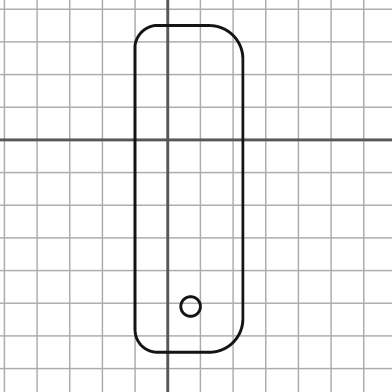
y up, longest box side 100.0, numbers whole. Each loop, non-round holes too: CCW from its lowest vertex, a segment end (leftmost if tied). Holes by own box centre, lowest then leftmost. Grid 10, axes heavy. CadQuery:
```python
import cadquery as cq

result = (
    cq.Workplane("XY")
    .moveTo(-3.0, -65.0)
    .lineTo(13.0, -65.0)
    .threePointArc((20.0, -62.0), (23.0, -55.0))
    .lineTo(23.0, 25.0)
    .threePointArc((20.0, 32.0), (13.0, 35.0))
    .lineTo(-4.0, 35.0)
    .threePointArc((-8.0, 33.0), (-10.0, 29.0))
    .lineTo(-10.0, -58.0)
    .threePointArc((-8.0, -63.0), (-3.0, -65.0))
    .close()
    .moveTo(7.0, -51.0)
    .circle(3.0)
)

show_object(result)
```